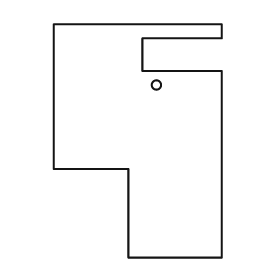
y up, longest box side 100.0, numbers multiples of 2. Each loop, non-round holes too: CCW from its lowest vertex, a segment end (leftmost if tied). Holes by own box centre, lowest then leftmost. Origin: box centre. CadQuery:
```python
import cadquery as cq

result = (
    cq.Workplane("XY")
    .moveTo(-4.0, -50.0)
    .lineTo(36.0, -50.0)
    .lineTo(36.0, 30.0)
    .lineTo(2.0, 30.0)
    .lineTo(2.0, 44.0)
    .lineTo(36.0, 44.0)
    .lineTo(36.0, 50.0)
    .lineTo(-36.0, 50.0)
    .lineTo(-36.0, -12.0)
    .lineTo(-4.0, -12.0)
    .close()
    .moveTo(8.0, 24.0)
    .circle(2.0)
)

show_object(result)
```